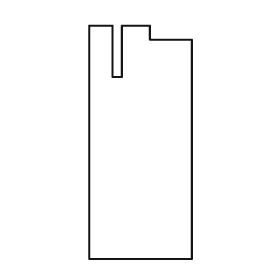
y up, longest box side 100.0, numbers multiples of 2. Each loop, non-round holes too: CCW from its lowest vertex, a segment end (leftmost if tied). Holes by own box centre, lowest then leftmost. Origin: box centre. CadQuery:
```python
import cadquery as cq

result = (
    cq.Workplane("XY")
    .moveTo(-22.0, -50.0)
    .lineTo(22.0, -50.0)
    .lineTo(22.0, 44.0)
    .lineTo(4.0, 44.0)
    .lineTo(4.0, 50.0)
    .lineTo(-8.0, 50.0)
    .lineTo(-8.0, 28.0)
    .lineTo(-12.0, 28.0)
    .lineTo(-12.0, 50.0)
    .lineTo(-22.0, 50.0)
    .close()
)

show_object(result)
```